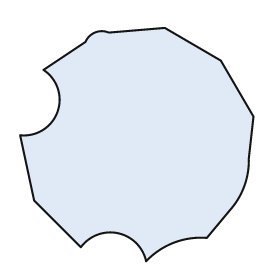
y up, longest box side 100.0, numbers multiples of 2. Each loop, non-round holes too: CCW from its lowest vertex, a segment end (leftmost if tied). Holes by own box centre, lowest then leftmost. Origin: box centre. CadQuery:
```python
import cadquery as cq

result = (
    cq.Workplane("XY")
    .moveTo(4.0, -50.0)
    .threePointArc((16.0, -42.0), (30.0, -40.0))
    .lineTo(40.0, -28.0)
    .threePointArc((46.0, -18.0), (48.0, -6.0))
    .lineTo(50.0, 12.0)
    .lineTo(36.0, 36.0)
    .lineTo(12.0, 50.0)
    .lineTo(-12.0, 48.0)
    .threePointArc((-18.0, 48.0), (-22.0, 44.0))
    .lineTo(-40.0, 32.0)
    .threePointArc((-34.0, 14.0), (-50.0, 4.0))
    .lineTo(-44.0, -24.0)
    .lineTo(-24.0, -44.0)
    .threePointArc((-8.0, -38.0), (4.0, -50.0))
    .close()
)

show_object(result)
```